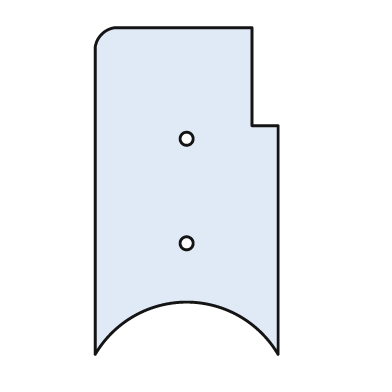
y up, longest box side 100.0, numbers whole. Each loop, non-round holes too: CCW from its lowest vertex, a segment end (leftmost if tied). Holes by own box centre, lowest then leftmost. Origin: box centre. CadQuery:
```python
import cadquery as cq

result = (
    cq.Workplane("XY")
    .moveTo(-28.0, -50.0)
    .threePointArc((0.0, -34.0), (28.0, -50.0))
    .lineTo(28.0, 20.0)
    .lineTo(20.0, 20.0)
    .lineTo(20.0, 50.0)
    .lineTo(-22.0, 50.0)
    .threePointArc((-26.0, 48.0), (-28.0, 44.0))
    .close()
    .moveTo(0.0, -16.0)
    .circle(2.0)
    .moveTo(0.0, 16.0)
    .circle(2.0)
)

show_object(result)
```